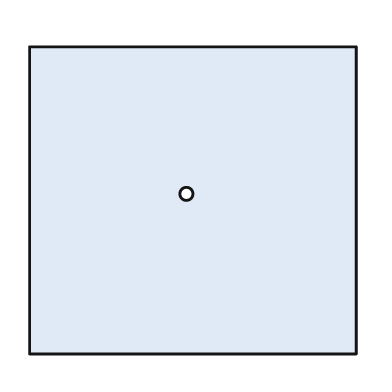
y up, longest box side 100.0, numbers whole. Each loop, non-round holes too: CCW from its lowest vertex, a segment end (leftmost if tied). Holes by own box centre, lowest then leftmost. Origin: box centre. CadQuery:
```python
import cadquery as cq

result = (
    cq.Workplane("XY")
    .moveTo(-50.0, -47.0)
    .lineTo(50.0, -47.0)
    .lineTo(50.0, 47.0)
    .lineTo(-50.0, 47.0)
    .close()
    .moveTo(-2.0, 2.0)
    .circle(2.0)
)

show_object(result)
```